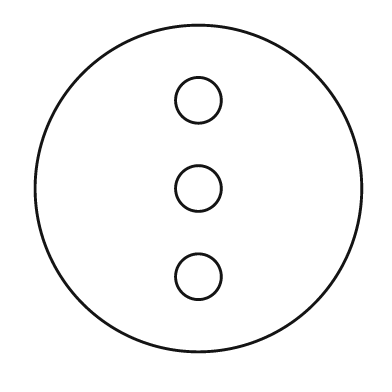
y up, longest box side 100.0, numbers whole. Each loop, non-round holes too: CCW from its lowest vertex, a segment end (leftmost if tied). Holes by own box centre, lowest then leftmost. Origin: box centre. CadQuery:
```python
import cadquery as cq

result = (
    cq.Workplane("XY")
    .moveTo(0.0, 0.0)
    .circle(50.0)
    .moveTo(0.0, -27.0)
    .circle(7.0)
    .moveTo(0.0, 0.0)
    .circle(7.0)
    .moveTo(0.0, 27.0)
    .circle(7.0)
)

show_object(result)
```